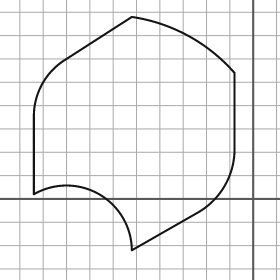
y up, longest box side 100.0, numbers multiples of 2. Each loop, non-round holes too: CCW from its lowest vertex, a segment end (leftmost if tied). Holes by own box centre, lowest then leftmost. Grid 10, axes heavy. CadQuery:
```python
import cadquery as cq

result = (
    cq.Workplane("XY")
    .moveTo(-52.0, -22.0)
    .lineTo(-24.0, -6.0)
    .threePointArc((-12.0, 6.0), (-8.0, 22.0))
    .lineTo(-8.0, 54.0)
    .threePointArc((-28.0, 70.0), (-52.0, 78.0))
    .lineTo(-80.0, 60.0)
    .threePointArc((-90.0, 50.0), (-94.0, 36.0))
    .lineTo(-94.0, 2.0)
    .threePointArc((-66.0, 2.0), (-52.0, -22.0))
    .close()
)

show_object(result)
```